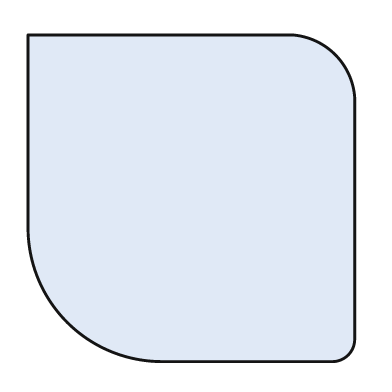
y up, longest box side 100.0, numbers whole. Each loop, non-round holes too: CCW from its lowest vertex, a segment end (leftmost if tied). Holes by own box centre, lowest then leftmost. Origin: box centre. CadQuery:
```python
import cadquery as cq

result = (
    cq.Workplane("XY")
    .moveTo(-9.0, -50.0)
    .lineTo(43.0, -50.0)
    .threePointArc((48.0, -48.0), (50.0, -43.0))
    .lineTo(50.0, 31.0)
    .threePointArc((44.0, 44.0), (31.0, 50.0))
    .lineTo(-50.0, 50.0)
    .lineTo(-50.0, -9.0)
    .threePointArc((-38.0, -38.0), (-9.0, -50.0))
    .close()
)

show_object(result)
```